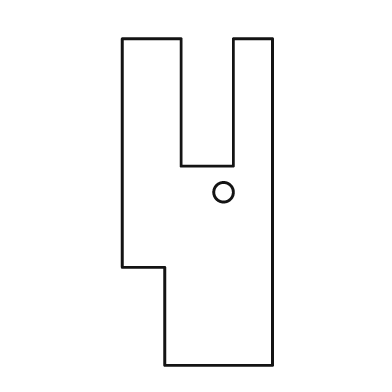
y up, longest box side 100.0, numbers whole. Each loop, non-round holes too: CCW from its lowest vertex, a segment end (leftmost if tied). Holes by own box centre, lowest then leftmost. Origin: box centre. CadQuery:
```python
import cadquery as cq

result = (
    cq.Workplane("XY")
    .moveTo(-10.0, -50.0)
    .lineTo(23.0, -50.0)
    .lineTo(23.0, 50.0)
    .lineTo(11.0, 50.0)
    .lineTo(11.0, 11.0)
    .lineTo(-5.0, 11.0)
    .lineTo(-5.0, 50.0)
    .lineTo(-23.0, 50.0)
    .lineTo(-23.0, -20.0)
    .lineTo(-10.0, -20.0)
    .close()
    .moveTo(8.0, 3.0)
    .circle(3.0)
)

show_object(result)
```